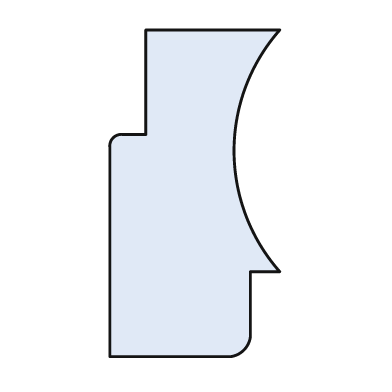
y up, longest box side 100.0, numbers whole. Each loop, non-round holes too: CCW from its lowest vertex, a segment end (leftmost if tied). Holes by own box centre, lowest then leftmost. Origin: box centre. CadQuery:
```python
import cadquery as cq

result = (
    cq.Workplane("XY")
    .moveTo(-26.0, -50.0)
    .lineTo(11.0, -50.0)
    .threePointArc((15.0, -48.0), (17.0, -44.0))
    .lineTo(17.0, -24.0)
    .lineTo(26.0, -24.0)
    .threePointArc((12.0, 13.0), (26.0, 50.0))
    .lineTo(-15.0, 50.0)
    .lineTo(-15.0, 18.0)
    .lineTo(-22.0, 18.0)
    .threePointArc((-25.0, 17.0), (-26.0, 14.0))
    .close()
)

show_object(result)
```